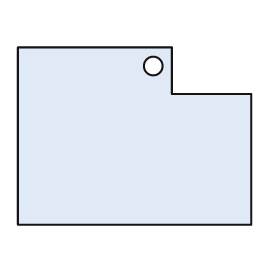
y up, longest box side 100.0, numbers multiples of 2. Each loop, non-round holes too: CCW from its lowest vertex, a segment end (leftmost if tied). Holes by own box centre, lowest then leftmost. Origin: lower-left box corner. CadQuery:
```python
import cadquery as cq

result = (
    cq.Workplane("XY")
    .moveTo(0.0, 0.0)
    .lineTo(100.0, 0.0)
    .lineTo(100.0, 56.0)
    .lineTo(66.0, 56.0)
    .lineTo(66.0, 76.0)
    .lineTo(0.0, 76.0)
    .close()
    .moveTo(58.0, 68.0)
    .circle(4.0)
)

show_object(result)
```